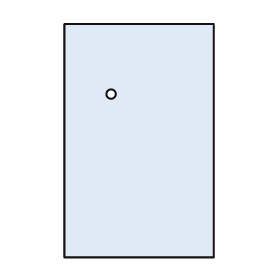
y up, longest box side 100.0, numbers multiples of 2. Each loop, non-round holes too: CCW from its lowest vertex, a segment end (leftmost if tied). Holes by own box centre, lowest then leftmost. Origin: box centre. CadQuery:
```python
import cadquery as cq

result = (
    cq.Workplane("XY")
    .moveTo(-32.0, -50.0)
    .lineTo(32.0, -50.0)
    .lineTo(32.0, 50.0)
    .lineTo(-32.0, 50.0)
    .close()
    .moveTo(-12.0, 20.0)
    .circle(2.0)
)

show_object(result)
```